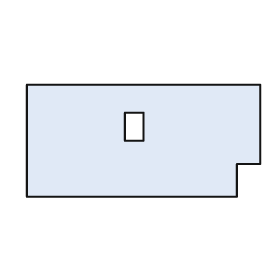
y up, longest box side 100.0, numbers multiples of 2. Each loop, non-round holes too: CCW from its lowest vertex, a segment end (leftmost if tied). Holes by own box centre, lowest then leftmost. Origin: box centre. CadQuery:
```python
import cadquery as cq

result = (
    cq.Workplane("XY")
    .moveTo(-50.0, -24.0)
    .lineTo(40.0, -24.0)
    .lineTo(40.0, -10.0)
    .lineTo(50.0, -10.0)
    .lineTo(50.0, 24.0)
    .lineTo(-50.0, 24.0)
    .close()
    .moveTo(-8.0, 0.0)
    .lineTo(0.0, 0.0)
    .lineTo(0.0, 12.0)
    .lineTo(-8.0, 12.0)
    .close()
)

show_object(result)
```